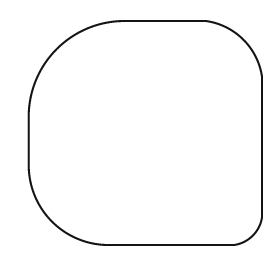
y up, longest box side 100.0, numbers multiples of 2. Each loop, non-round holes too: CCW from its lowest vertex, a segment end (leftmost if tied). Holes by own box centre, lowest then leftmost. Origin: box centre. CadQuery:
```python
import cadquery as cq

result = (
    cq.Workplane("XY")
    .moveTo(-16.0, -48.0)
    .lineTo(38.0, -48.0)
    .threePointArc((46.0, -44.0), (50.0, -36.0))
    .lineTo(50.0, 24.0)
    .threePointArc((42.0, 40.0), (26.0, 48.0))
    .lineTo(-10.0, 48.0)
    .threePointArc((-38.0, 36.0), (-50.0, 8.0))
    .lineTo(-50.0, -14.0)
    .threePointArc((-40.0, -38.0), (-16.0, -48.0))
    .close()
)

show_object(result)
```